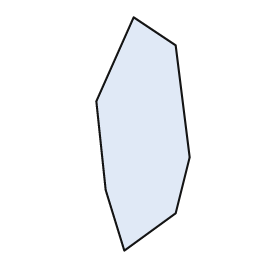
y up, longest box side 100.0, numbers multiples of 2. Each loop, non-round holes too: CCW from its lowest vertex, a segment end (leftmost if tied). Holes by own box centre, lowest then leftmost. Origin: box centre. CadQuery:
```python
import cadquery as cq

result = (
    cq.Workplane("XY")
    .moveTo(-8.0, -50.0)
    .lineTo(14.0, -34.0)
    .lineTo(20.0, -10.0)
    .lineTo(14.0, 38.0)
    .lineTo(-4.0, 50.0)
    .lineTo(-20.0, 14.0)
    .lineTo(-16.0, -24.0)
    .close()
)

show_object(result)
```